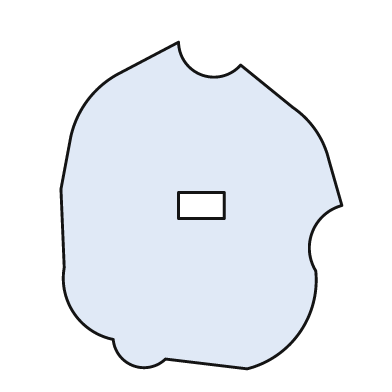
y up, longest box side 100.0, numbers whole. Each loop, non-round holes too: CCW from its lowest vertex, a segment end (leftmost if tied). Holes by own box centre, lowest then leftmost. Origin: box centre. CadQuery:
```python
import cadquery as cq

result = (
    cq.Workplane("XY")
    .moveTo(14.0, -50.0)
    .threePointArc((30.0, -39.0), (35.0, -20.0))
    .threePointArc((34.0, -8.0), (43.0, 0.0))
    .lineTo(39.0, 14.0)
    .threePointArc((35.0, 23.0), (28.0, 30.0))
    .lineTo(12.0, 43.0)
    .threePointArc((0.0, 40.0), (-7.0, 50.0))
    .lineTo(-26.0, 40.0)
    .threePointArc((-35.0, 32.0), (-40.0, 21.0))
    .lineTo(-43.0, 5.0)
    .lineTo(-42.0, -19.0)
    .threePointArc((-39.0, -33.0), (-27.0, -41.0))
    .threePointArc((-21.0, -49.0), (-11.0, -47.0))
    .close()
    .moveTo(-7.0, -4.0)
    .lineTo(7.0, -4.0)
    .lineTo(7.0, 4.0)
    .lineTo(-7.0, 4.0)
    .close()
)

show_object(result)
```